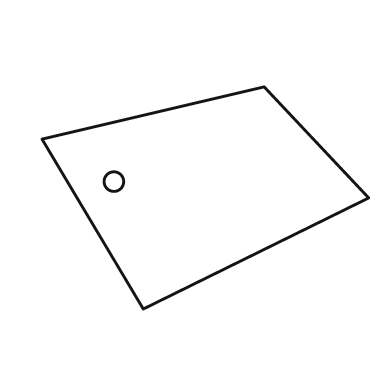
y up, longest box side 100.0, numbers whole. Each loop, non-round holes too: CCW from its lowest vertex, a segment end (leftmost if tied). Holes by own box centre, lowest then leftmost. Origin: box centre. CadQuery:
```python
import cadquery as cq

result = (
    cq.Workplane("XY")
    .moveTo(-19.0, -34.0)
    .lineTo(50.0, 0.0)
    .lineTo(18.0, 34.0)
    .lineTo(-50.0, 18.0)
    .close()
    .moveTo(-28.0, 5.0)
    .circle(3.0)
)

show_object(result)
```